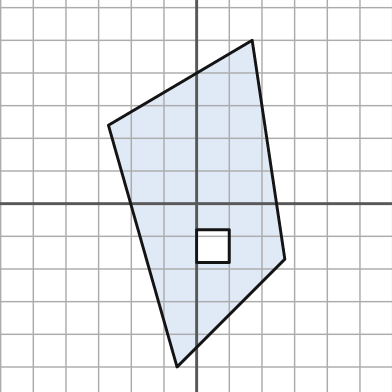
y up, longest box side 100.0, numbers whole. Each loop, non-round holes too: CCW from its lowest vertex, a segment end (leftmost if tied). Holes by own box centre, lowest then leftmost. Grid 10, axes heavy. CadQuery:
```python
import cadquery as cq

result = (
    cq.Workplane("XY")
    .moveTo(-6.0, -50.0)
    .lineTo(27.0, -17.0)
    .lineTo(17.0, 50.0)
    .lineTo(-27.0, 24.0)
    .close()
    .moveTo(0.0, -18.0)
    .lineTo(10.0, -18.0)
    .lineTo(10.0, -8.0)
    .lineTo(0.0, -8.0)
    .close()
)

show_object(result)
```